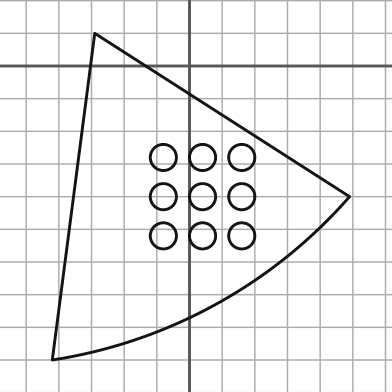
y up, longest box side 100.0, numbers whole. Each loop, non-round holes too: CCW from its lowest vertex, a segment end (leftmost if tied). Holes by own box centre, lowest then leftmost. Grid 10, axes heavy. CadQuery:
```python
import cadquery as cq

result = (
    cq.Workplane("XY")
    .moveTo(-42.0, -90.0)
    .threePointArc((8.0, -73.0), (49.0, -40.0))
    .lineTo(-29.0, 10.0)
    .close()
    .moveTo(-8.0, -52.0)
    .circle(4.0)
    .moveTo(4.0, -52.0)
    .circle(4.0)
    .moveTo(16.0, -52.0)
    .circle(4.0)
    .moveTo(-8.0, -40.0)
    .circle(4.0)
    .moveTo(4.0, -40.0)
    .circle(4.0)
    .moveTo(16.0, -40.0)
    .circle(4.0)
    .moveTo(-8.0, -28.0)
    .circle(4.0)
    .moveTo(4.0, -28.0)
    .circle(4.0)
    .moveTo(16.0, -28.0)
    .circle(4.0)
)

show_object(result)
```